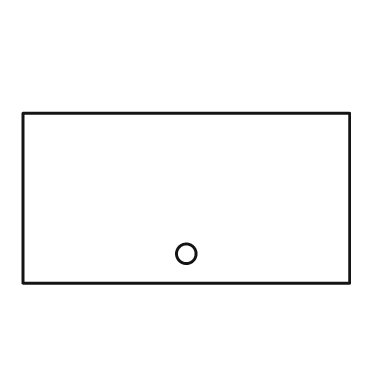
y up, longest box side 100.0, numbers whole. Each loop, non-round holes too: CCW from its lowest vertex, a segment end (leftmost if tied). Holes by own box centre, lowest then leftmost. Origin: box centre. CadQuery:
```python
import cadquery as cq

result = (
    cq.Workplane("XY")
    .moveTo(-50.0, -26.0)
    .lineTo(50.0, -26.0)
    .lineTo(50.0, 26.0)
    .lineTo(-50.0, 26.0)
    .close()
    .moveTo(0.0, -17.0)
    .circle(3.0)
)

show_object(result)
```